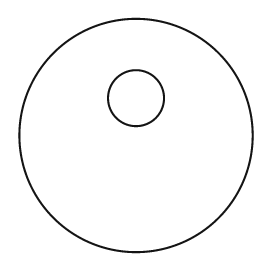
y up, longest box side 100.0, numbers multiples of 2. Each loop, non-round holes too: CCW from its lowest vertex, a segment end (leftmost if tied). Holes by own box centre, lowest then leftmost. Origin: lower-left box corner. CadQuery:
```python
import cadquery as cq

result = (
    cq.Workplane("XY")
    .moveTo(50.0, 50.0)
    .circle(50.0)
    .moveTo(50.0, 66.0)
    .circle(12.0)
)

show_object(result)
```